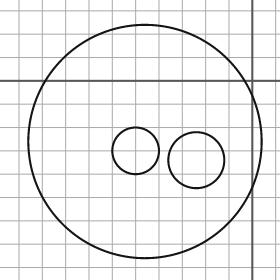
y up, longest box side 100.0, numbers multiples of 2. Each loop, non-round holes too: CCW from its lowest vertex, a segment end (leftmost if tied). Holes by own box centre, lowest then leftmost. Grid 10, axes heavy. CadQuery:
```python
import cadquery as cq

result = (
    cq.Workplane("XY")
    .moveTo(-46.0, -26.0)
    .circle(50.0)
    .moveTo(-24.0, -34.0)
    .circle(12.0)
    .moveTo(-50.0, -30.0)
    .circle(10.0)
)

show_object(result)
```